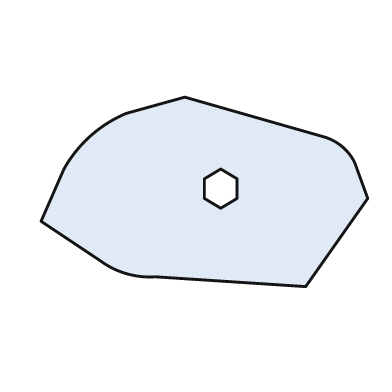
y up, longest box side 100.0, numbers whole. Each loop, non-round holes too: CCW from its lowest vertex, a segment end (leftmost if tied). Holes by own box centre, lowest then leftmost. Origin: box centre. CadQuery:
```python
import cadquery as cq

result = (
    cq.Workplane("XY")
    .moveTo(31.0, -29.0)
    .lineTo(50.0, -2.0)
    .lineTo(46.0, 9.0)
    .threePointArc((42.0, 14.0), (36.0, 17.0))
    .lineTo(-6.0, 29.0)
    .lineTo(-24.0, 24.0)
    .threePointArc((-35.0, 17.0), (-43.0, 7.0))
    .lineTo(-50.0, -9.0)
    .lineTo(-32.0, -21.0)
    .threePointArc((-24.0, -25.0), (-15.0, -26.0))
    .close()
    .moveTo(5.0, -5.0)
    .lineTo(10.0, -2.0)
    .lineTo(10.0, 4.0)
    .lineTo(5.0, 7.0)
    .lineTo(0.0, 4.0)
    .lineTo(0.0, -2.0)
    .close()
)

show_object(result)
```